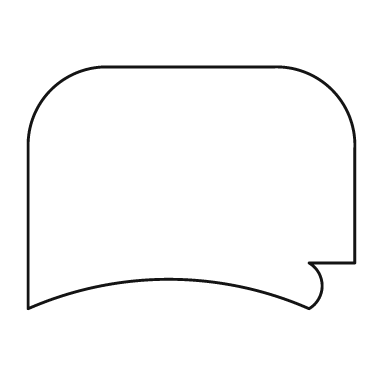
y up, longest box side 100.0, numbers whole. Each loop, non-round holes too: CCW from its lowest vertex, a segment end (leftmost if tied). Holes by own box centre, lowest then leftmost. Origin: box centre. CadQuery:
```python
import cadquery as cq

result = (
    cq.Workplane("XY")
    .moveTo(-50.0, -37.0)
    .threePointArc((-7.0, -28.0), (36.0, -37.0))
    .threePointArc((40.0, -30.0), (36.0, -23.0))
    .lineTo(50.0, -23.0)
    .lineTo(50.0, 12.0)
    .threePointArc((43.0, 30.0), (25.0, 37.0))
    .lineTo(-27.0, 37.0)
    .threePointArc((-43.0, 30.0), (-50.0, 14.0))
    .close()
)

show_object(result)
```